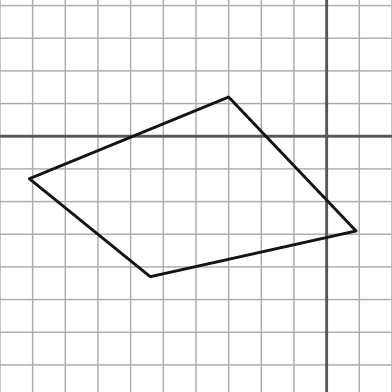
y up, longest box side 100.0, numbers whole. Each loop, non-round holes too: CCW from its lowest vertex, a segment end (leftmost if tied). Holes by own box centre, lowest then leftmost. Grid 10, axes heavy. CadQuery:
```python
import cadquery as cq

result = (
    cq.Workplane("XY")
    .moveTo(-54.0, -43.0)
    .lineTo(9.0, -29.0)
    .lineTo(-30.0, 12.0)
    .lineTo(-91.0, -13.0)
    .close()
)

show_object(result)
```